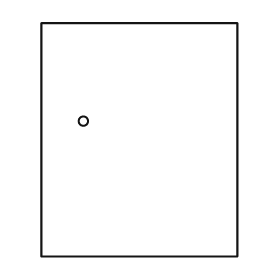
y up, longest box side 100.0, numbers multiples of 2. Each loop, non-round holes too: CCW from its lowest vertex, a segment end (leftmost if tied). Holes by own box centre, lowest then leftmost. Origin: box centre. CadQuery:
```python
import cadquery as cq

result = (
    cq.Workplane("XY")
    .moveTo(-42.0, -50.0)
    .lineTo(42.0, -50.0)
    .lineTo(42.0, 50.0)
    .lineTo(-42.0, 50.0)
    .close()
    .moveTo(-24.0, 8.0)
    .circle(2.0)
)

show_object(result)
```